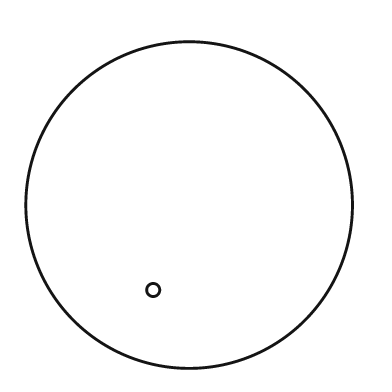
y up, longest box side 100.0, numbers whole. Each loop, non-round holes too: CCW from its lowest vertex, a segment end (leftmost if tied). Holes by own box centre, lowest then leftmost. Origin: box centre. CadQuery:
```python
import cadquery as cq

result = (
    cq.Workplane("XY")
    .moveTo(0.0, 0.0)
    .circle(50.0)
    .moveTo(-11.0, -26.0)
    .circle(2.0)
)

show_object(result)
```